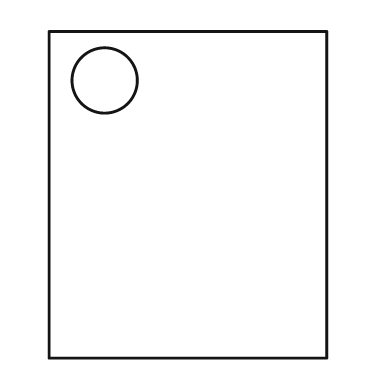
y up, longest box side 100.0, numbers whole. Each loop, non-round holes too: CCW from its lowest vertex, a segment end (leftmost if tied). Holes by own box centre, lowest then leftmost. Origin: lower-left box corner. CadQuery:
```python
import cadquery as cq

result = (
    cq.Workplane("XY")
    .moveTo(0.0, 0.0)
    .lineTo(85.0, 0.0)
    .lineTo(85.0, 100.0)
    .lineTo(0.0, 100.0)
    .close()
    .moveTo(17.0, 85.0)
    .circle(10.0)
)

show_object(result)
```